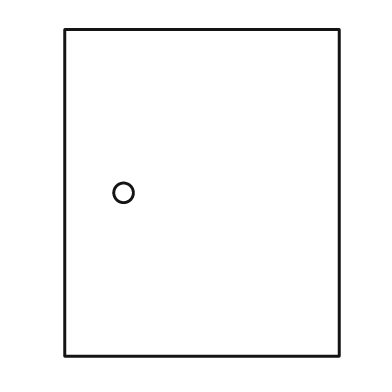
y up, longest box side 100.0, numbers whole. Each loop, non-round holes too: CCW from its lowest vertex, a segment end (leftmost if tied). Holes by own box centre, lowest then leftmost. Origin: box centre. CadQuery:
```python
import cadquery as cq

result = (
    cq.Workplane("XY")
    .moveTo(-42.0, -50.0)
    .lineTo(42.0, -50.0)
    .lineTo(42.0, 50.0)
    .lineTo(-42.0, 50.0)
    .close()
    .moveTo(-24.0, 0.0)
    .circle(3.0)
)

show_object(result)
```